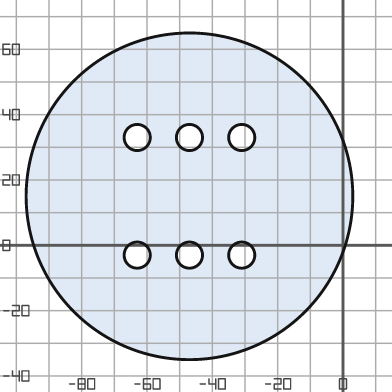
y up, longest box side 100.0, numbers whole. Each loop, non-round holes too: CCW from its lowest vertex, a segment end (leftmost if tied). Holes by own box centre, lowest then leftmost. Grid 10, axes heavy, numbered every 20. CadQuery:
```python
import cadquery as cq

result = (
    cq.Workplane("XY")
    .moveTo(-47.0, 15.0)
    .circle(50.0)
    .moveTo(-63.0, -3.0)
    .circle(4.0)
    .moveTo(-47.0, -3.0)
    .circle(4.0)
    .moveTo(-31.0, -3.0)
    .circle(4.0)
    .moveTo(-63.0, 33.0)
    .circle(4.0)
    .moveTo(-47.0, 33.0)
    .circle(4.0)
    .moveTo(-31.0, 33.0)
    .circle(4.0)
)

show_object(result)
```